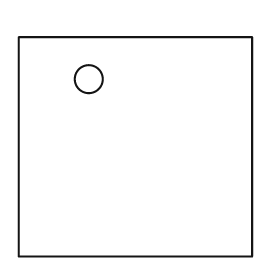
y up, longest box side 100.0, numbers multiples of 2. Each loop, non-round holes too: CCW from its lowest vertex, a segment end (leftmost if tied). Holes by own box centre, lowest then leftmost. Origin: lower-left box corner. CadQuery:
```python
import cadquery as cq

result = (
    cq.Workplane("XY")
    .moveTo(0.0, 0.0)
    .lineTo(100.0, 0.0)
    .lineTo(100.0, 94.0)
    .lineTo(0.0, 94.0)
    .close()
    .moveTo(30.0, 76.0)
    .circle(6.0)
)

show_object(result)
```